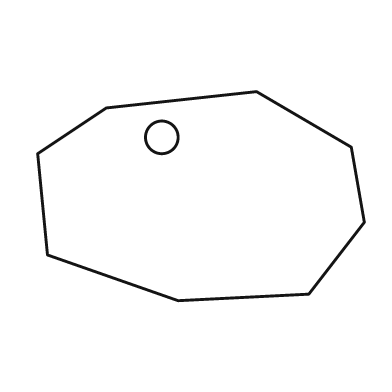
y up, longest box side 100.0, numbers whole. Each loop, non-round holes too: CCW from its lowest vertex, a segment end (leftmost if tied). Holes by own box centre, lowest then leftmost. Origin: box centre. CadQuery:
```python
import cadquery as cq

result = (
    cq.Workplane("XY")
    .moveTo(-7.0, -32.0)
    .lineTo(33.0, -30.0)
    .lineTo(50.0, -8.0)
    .lineTo(46.0, 15.0)
    .lineTo(17.0, 32.0)
    .lineTo(-29.0, 27.0)
    .lineTo(-50.0, 13.0)
    .lineTo(-47.0, -18.0)
    .close()
    .moveTo(-12.0, 18.0)
    .circle(5.0)
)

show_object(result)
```